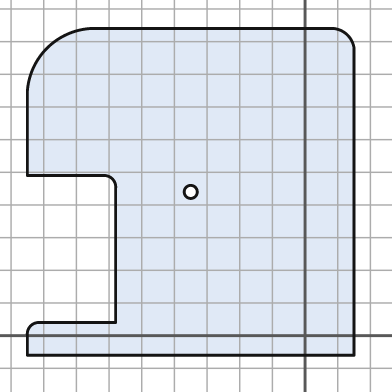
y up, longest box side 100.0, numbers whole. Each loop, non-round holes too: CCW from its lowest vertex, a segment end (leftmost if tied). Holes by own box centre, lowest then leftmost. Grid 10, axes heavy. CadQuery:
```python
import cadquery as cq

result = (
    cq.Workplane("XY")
    .moveTo(-85.0, -6.0)
    .lineTo(15.0, -6.0)
    .lineTo(15.0, 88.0)
    .threePointArc((13.0, 92.0), (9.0, 94.0))
    .lineTo(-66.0, 94.0)
    .threePointArc((-79.0, 88.0), (-85.0, 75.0))
    .lineTo(-85.0, 49.0)
    .lineTo(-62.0, 49.0)
    .threePointArc((-59.0, 48.0), (-58.0, 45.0))
    .lineTo(-58.0, 4.0)
    .lineTo(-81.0, 4.0)
    .threePointArc((-84.0, 3.0), (-85.0, 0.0))
    .close()
    .moveTo(-35.0, 44.0)
    .circle(2.0)
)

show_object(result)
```